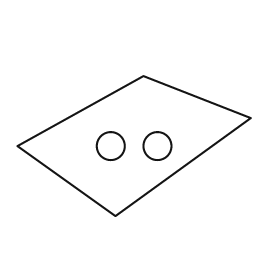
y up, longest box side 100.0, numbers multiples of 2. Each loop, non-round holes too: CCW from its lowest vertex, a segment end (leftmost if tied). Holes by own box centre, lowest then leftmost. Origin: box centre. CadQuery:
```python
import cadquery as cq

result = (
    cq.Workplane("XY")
    .moveTo(-8.0, -30.0)
    .lineTo(50.0, 12.0)
    .lineTo(4.0, 30.0)
    .lineTo(-50.0, 0.0)
    .close()
    .moveTo(-10.0, 0.0)
    .circle(6.0)
    .moveTo(10.0, 0.0)
    .circle(6.0)
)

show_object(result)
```